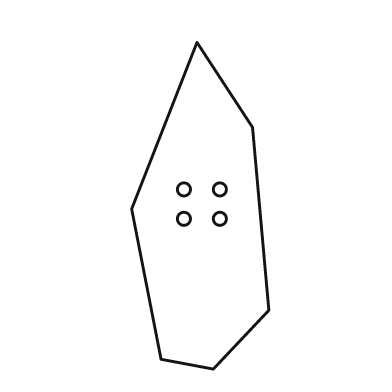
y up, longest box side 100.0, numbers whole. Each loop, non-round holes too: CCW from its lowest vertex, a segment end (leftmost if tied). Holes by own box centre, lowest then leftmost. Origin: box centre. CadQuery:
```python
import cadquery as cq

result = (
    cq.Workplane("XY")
    .moveTo(4.0, -50.0)
    .lineTo(21.0, -32.0)
    .lineTo(16.0, 24.0)
    .lineTo(-1.0, 50.0)
    .lineTo(-21.0, -1.0)
    .lineTo(-12.0, -47.0)
    .close()
    .moveTo(-5.0, -4.0)
    .circle(2.0)
    .moveTo(6.0, -4.0)
    .circle(2.0)
    .moveTo(-5.0, 5.0)
    .circle(2.0)
    .moveTo(6.0, 5.0)
    .circle(2.0)
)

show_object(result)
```